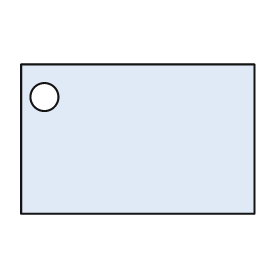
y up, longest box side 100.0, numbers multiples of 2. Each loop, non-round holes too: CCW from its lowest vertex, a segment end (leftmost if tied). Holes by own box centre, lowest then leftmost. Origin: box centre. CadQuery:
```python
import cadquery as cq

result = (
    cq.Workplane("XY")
    .moveTo(-50.0, -32.0)
    .lineTo(50.0, -32.0)
    .lineTo(50.0, 32.0)
    .lineTo(-50.0, 32.0)
    .close()
    .moveTo(-40.0, 18.0)
    .circle(6.0)
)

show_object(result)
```